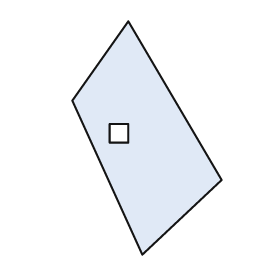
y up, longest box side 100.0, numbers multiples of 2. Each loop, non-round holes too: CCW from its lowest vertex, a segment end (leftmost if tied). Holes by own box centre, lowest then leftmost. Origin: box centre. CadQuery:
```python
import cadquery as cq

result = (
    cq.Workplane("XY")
    .moveTo(-2.0, -50.0)
    .lineTo(32.0, -18.0)
    .lineTo(-8.0, 50.0)
    .lineTo(-32.0, 16.0)
    .close()
    .moveTo(-16.0, -2.0)
    .lineTo(-8.0, -2.0)
    .lineTo(-8.0, 6.0)
    .lineTo(-16.0, 6.0)
    .close()
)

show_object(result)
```